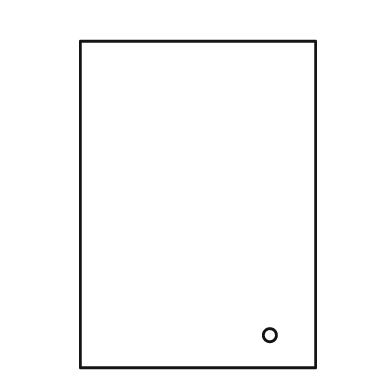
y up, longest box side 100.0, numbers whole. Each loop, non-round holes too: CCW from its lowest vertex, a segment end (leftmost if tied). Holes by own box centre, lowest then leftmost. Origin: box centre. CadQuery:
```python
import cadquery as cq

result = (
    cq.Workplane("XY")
    .moveTo(-36.0, -50.0)
    .lineTo(36.0, -50.0)
    .lineTo(36.0, 50.0)
    .lineTo(-36.0, 50.0)
    .close()
    .moveTo(22.0, -40.0)
    .circle(2.0)
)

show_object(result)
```